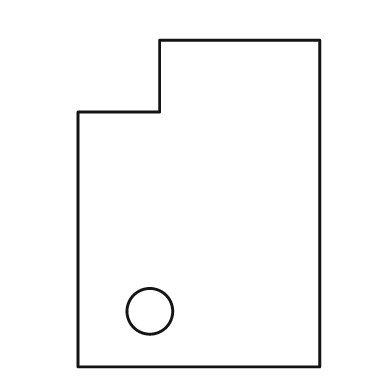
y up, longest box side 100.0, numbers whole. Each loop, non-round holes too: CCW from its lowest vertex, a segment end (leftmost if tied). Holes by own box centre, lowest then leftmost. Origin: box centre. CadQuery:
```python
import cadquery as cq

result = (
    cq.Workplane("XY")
    .moveTo(-37.0, -50.0)
    .lineTo(37.0, -50.0)
    .lineTo(37.0, 50.0)
    .lineTo(-12.0, 50.0)
    .lineTo(-12.0, 28.0)
    .lineTo(-37.0, 28.0)
    .close()
    .moveTo(-15.0, -33.0)
    .circle(7.0)
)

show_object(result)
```